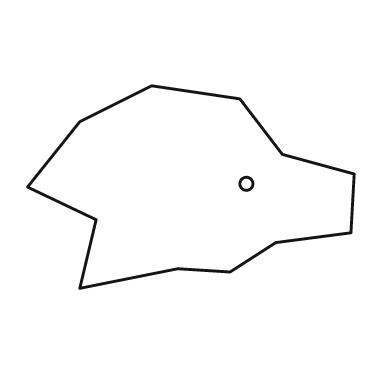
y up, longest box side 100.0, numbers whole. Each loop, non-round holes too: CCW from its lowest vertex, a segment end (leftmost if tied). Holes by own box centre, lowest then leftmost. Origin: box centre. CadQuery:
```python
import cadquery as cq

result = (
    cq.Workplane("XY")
    .moveTo(-34.0, -31.0)
    .lineTo(-4.0, -25.0)
    .lineTo(12.0, -26.0)
    .lineTo(26.0, -17.0)
    .lineTo(49.0, -14.0)
    .lineTo(50.0, 4.0)
    .lineTo(28.0, 10.0)
    .lineTo(15.0, 27.0)
    .lineTo(-12.0, 31.0)
    .lineTo(-34.0, 20.0)
    .lineTo(-50.0, 0.0)
    .lineTo(-29.0, -10.0)
    .close()
    .moveTo(17.0, 1.0)
    .circle(2.0)
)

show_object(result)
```